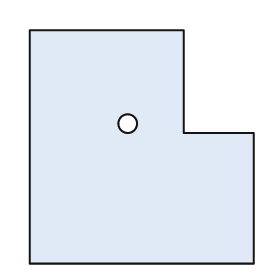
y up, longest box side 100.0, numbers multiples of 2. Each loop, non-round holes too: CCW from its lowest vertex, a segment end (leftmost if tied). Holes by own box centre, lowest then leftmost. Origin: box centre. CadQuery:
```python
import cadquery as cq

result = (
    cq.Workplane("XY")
    .moveTo(-48.0, -50.0)
    .lineTo(48.0, -50.0)
    .lineTo(48.0, 6.0)
    .lineTo(18.0, 6.0)
    .lineTo(18.0, 50.0)
    .lineTo(-48.0, 50.0)
    .close()
    .moveTo(-6.0, 10.0)
    .circle(4.0)
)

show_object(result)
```